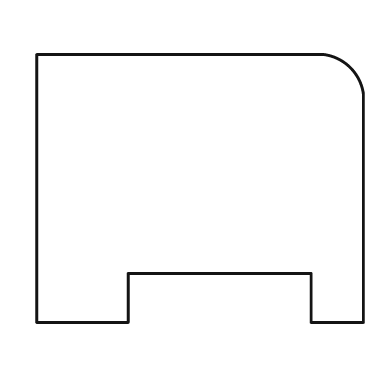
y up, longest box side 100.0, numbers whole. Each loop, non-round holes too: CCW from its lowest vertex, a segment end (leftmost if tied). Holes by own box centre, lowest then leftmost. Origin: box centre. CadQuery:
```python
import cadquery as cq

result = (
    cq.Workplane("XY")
    .moveTo(-50.0, -41.0)
    .lineTo(-22.0, -41.0)
    .lineTo(-22.0, -26.0)
    .lineTo(34.0, -26.0)
    .lineTo(34.0, -41.0)
    .lineTo(50.0, -41.0)
    .lineTo(50.0, 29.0)
    .threePointArc((46.0, 37.0), (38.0, 41.0))
    .lineTo(-50.0, 41.0)
    .close()
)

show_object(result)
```